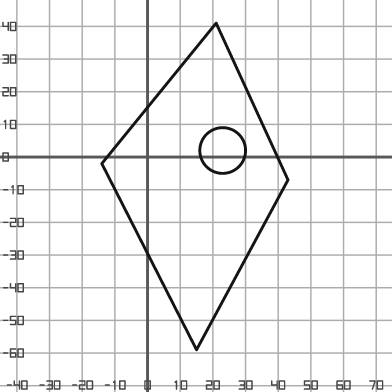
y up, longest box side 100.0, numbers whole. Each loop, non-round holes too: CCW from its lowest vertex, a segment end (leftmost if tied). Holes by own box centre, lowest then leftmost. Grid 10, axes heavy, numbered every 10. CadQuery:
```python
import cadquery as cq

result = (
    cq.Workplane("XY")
    .moveTo(15.0, -59.0)
    .lineTo(43.0, -7.0)
    .lineTo(21.0, 41.0)
    .lineTo(-14.0, -2.0)
    .close()
    .moveTo(23.0, 2.0)
    .circle(7.0)
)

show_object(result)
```